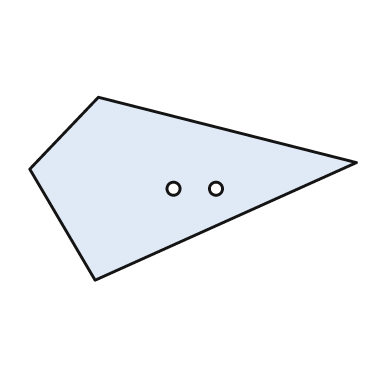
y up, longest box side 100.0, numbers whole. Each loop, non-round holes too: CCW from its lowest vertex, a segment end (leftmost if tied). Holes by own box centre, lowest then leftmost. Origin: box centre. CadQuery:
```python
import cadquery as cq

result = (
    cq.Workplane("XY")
    .moveTo(-30.0, -28.0)
    .lineTo(50.0, 8.0)
    .lineTo(-29.0, 28.0)
    .lineTo(-50.0, 6.0)
    .close()
    .moveTo(-6.0, 0.0)
    .circle(2.0)
    .moveTo(7.0, 0.0)
    .circle(2.0)
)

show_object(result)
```